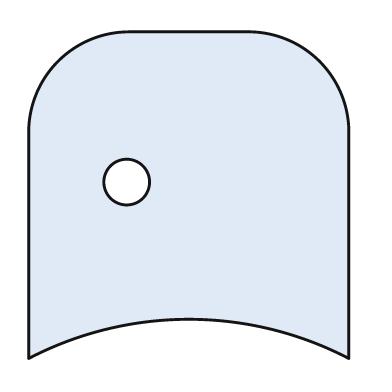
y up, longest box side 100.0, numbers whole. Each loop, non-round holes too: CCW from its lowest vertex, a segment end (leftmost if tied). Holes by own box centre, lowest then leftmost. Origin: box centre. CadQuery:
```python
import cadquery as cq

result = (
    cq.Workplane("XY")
    .moveTo(-49.0, -50.0)
    .threePointArc((0.0, -38.0), (49.0, -50.0))
    .lineTo(49.0, 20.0)
    .threePointArc((40.0, 41.0), (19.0, 50.0))
    .lineTo(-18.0, 50.0)
    .threePointArc((-40.0, 41.0), (-49.0, 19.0))
    .close()
    .moveTo(-19.0, 4.0)
    .circle(7.0)
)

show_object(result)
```